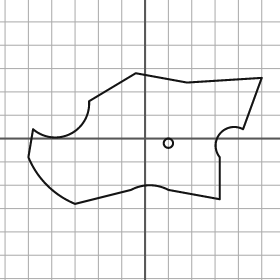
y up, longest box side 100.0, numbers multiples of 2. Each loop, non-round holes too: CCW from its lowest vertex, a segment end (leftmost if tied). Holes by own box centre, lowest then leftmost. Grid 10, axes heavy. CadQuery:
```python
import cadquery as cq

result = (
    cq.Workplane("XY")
    .moveTo(-30.0, -28.0)
    .lineTo(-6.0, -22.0)
    .threePointArc((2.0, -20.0), (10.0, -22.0))
    .lineTo(32.0, -26.0)
    .lineTo(32.0, -8.0)
    .threePointArc((32.0, 2.0), (42.0, 4.0))
    .lineTo(50.0, 26.0)
    .lineTo(18.0, 24.0)
    .lineTo(-4.0, 28.0)
    .lineTo(-24.0, 16.0)
    .threePointArc((-32.0, 2.0), (-48.0, 4.0))
    .lineTo(-50.0, -8.0)
    .threePointArc((-42.0, -20.0), (-30.0, -28.0))
    .close()
    .moveTo(10.0, -2.0)
    .circle(2.0)
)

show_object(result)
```